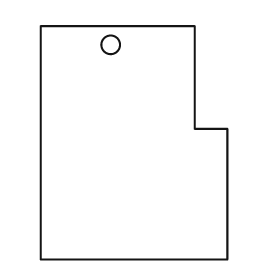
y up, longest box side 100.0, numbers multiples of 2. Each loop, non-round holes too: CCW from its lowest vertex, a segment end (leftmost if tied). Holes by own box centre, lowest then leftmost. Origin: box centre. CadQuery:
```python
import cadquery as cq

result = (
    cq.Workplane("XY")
    .moveTo(-40.0, -50.0)
    .lineTo(40.0, -50.0)
    .lineTo(40.0, 6.0)
    .lineTo(26.0, 6.0)
    .lineTo(26.0, 50.0)
    .lineTo(-40.0, 50.0)
    .close()
    .moveTo(-10.0, 42.0)
    .circle(4.0)
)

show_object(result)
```